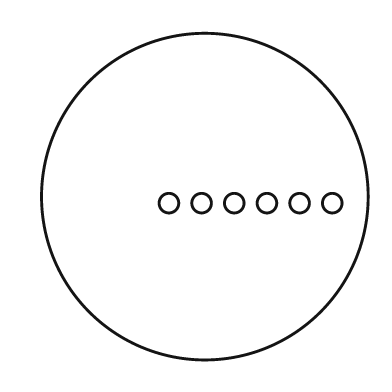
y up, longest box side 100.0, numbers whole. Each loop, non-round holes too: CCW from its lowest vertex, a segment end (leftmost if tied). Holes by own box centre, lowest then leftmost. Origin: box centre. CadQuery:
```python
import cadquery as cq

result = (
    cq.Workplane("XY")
    .moveTo(0.0, 0.0)
    .circle(50.0)
    .moveTo(-11.0, -2.0)
    .circle(3.0)
    .moveTo(-1.0, -2.0)
    .circle(3.0)
    .moveTo(9.0, -2.0)
    .circle(3.0)
    .moveTo(19.0, -2.0)
    .circle(3.0)
    .moveTo(29.0, -2.0)
    .circle(3.0)
    .moveTo(39.0, -2.0)
    .circle(3.0)
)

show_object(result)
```